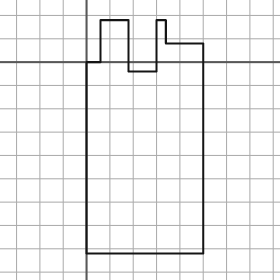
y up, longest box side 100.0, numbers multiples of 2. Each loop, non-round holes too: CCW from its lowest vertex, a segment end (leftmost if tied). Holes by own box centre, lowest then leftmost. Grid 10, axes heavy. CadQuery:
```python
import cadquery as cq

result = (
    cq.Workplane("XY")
    .moveTo(0.0, -82.0)
    .lineTo(50.0, -82.0)
    .lineTo(50.0, 8.0)
    .lineTo(34.0, 8.0)
    .lineTo(34.0, 18.0)
    .lineTo(30.0, 18.0)
    .lineTo(30.0, -4.0)
    .lineTo(18.0, -4.0)
    .lineTo(18.0, 18.0)
    .lineTo(6.0, 18.0)
    .lineTo(6.0, 0.0)
    .lineTo(0.0, 0.0)
    .close()
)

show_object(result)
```